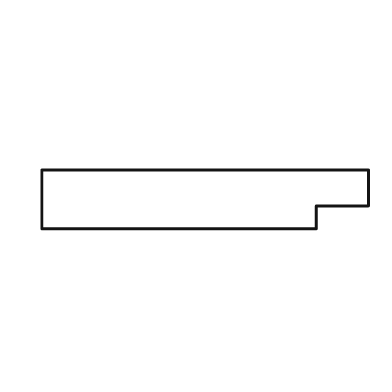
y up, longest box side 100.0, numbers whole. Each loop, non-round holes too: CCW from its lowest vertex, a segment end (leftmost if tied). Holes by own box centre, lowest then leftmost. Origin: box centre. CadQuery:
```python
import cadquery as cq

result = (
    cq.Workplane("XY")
    .moveTo(-50.0, -9.0)
    .lineTo(34.0, -9.0)
    .lineTo(34.0, -2.0)
    .lineTo(50.0, -2.0)
    .lineTo(50.0, 9.0)
    .lineTo(-50.0, 9.0)
    .close()
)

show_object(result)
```